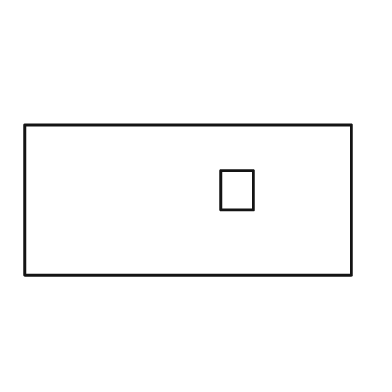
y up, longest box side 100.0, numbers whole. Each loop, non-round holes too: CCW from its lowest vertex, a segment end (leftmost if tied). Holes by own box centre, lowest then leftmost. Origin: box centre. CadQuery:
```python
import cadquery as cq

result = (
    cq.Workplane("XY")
    .moveTo(-50.0, -23.0)
    .lineTo(50.0, -23.0)
    .lineTo(50.0, 23.0)
    .lineTo(-50.0, 23.0)
    .close()
    .moveTo(10.0, -3.0)
    .lineTo(20.0, -3.0)
    .lineTo(20.0, 9.0)
    .lineTo(10.0, 9.0)
    .close()
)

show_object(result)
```